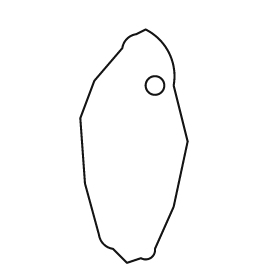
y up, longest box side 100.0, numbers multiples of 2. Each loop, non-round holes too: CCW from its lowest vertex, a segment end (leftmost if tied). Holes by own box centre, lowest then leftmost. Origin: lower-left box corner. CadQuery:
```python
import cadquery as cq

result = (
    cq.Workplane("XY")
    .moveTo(20.0, 0.0)
    .lineTo(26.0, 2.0)
    .threePointArc((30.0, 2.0), (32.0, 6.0))
    .lineTo(40.0, 24.0)
    .lineTo(46.0, 52.0)
    .lineTo(40.0, 76.0)
    .threePointArc((38.0, 90.0), (28.0, 100.0))
    .lineTo(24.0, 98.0)
    .threePointArc((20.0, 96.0), (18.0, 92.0))
    .lineTo(6.0, 78.0)
    .lineTo(0.0, 62.0)
    .lineTo(2.0, 34.0)
    .lineTo(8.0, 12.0)
    .threePointArc((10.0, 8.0), (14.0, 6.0))
    .close()
    .moveTo(32.0, 76.0)
    .circle(4.0)
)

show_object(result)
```